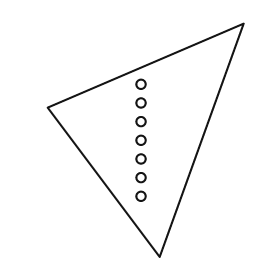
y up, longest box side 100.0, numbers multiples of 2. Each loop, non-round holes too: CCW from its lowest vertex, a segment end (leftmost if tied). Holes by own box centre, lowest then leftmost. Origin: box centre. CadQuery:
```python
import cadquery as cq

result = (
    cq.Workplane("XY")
    .moveTo(6.0, -50.0)
    .lineTo(42.0, 50.0)
    .lineTo(-42.0, 14.0)
    .close()
    .moveTo(-2.0, -24.0)
    .circle(2.0)
    .moveTo(-2.0, -16.0)
    .circle(2.0)
    .moveTo(-2.0, -8.0)
    .circle(2.0)
    .moveTo(-2.0, 0.0)
    .circle(2.0)
    .moveTo(-2.0, 8.0)
    .circle(2.0)
    .moveTo(-2.0, 16.0)
    .circle(2.0)
    .moveTo(-2.0, 24.0)
    .circle(2.0)
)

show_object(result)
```